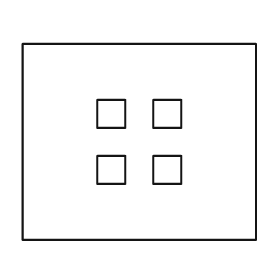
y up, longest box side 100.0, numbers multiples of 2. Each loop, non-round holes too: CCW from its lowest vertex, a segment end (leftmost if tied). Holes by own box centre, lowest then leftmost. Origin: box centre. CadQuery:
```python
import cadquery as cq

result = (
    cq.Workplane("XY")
    .moveTo(-50.0, -42.0)
    .lineTo(50.0, -42.0)
    .lineTo(50.0, 42.0)
    .lineTo(-50.0, 42.0)
    .close()
    .moveTo(-18.0, -18.0)
    .lineTo(-6.0, -18.0)
    .lineTo(-6.0, -6.0)
    .lineTo(-18.0, -6.0)
    .close()
    .moveTo(6.0, -18.0)
    .lineTo(18.0, -18.0)
    .lineTo(18.0, -6.0)
    .lineTo(6.0, -6.0)
    .close()
    .moveTo(-18.0, 6.0)
    .lineTo(-6.0, 6.0)
    .lineTo(-6.0, 18.0)
    .lineTo(-18.0, 18.0)
    .close()
    .moveTo(6.0, 6.0)
    .lineTo(18.0, 6.0)
    .lineTo(18.0, 18.0)
    .lineTo(6.0, 18.0)
    .close()
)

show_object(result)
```